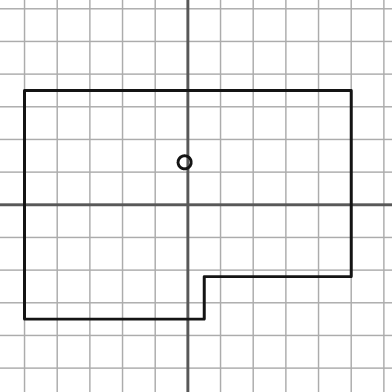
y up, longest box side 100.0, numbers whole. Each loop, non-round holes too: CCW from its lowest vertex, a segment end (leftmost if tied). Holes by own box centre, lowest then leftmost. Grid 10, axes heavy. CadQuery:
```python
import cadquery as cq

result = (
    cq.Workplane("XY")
    .moveTo(-50.0, -35.0)
    .lineTo(5.0, -35.0)
    .lineTo(5.0, -22.0)
    .lineTo(50.0, -22.0)
    .lineTo(50.0, 35.0)
    .lineTo(-50.0, 35.0)
    .close()
    .moveTo(-1.0, 13.0)
    .circle(2.0)
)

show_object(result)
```